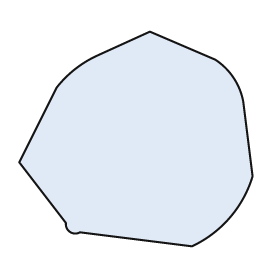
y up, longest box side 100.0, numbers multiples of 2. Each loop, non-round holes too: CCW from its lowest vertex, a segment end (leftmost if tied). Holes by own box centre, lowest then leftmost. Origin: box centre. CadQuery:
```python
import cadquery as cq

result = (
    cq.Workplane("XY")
    .moveTo(24.0, -46.0)
    .threePointArc((40.0, -34.0), (50.0, -16.0))
    .lineTo(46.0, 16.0)
    .threePointArc((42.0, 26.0), (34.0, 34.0))
    .lineTo(6.0, 46.0)
    .lineTo(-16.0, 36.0)
    .threePointArc((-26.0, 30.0), (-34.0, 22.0))
    .lineTo(-50.0, -10.0)
    .lineTo(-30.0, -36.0)
    .threePointArc((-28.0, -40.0), (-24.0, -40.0))
    .close()
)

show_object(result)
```